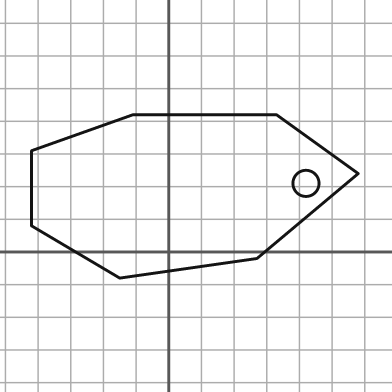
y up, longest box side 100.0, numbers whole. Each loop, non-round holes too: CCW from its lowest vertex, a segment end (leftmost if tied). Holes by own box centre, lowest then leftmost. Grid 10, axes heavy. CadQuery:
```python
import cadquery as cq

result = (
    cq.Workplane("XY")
    .moveTo(-15.0, -8.0)
    .lineTo(27.0, -2.0)
    .lineTo(58.0, 24.0)
    .lineTo(33.0, 42.0)
    .lineTo(-11.0, 42.0)
    .lineTo(-42.0, 31.0)
    .lineTo(-42.0, 8.0)
    .close()
    .moveTo(42.0, 21.0)
    .circle(4.0)
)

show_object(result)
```